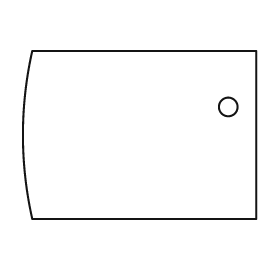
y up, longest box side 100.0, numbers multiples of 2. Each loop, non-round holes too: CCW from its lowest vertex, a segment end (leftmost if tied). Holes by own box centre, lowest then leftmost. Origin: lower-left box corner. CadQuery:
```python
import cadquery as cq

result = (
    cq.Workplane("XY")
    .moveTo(4.0, 0.0)
    .lineTo(100.0, 0.0)
    .lineTo(100.0, 72.0)
    .lineTo(4.0, 72.0)
    .threePointArc((0.0, 36.0), (4.0, 0.0))
    .close()
    .moveTo(88.0, 48.0)
    .circle(4.0)
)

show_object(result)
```